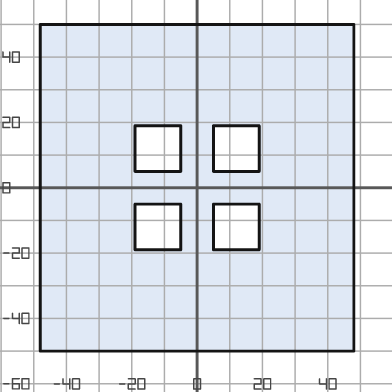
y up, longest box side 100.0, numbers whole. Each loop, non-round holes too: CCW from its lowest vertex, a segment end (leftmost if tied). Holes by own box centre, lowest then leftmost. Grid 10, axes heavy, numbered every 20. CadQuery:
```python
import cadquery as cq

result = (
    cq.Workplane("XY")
    .moveTo(-48.0, -50.0)
    .lineTo(48.0, -50.0)
    .lineTo(48.0, 50.0)
    .lineTo(-48.0, 50.0)
    .close()
    .moveTo(-19.0, -19.0)
    .lineTo(-5.0, -19.0)
    .lineTo(-5.0, -5.0)
    .lineTo(-19.0, -5.0)
    .close()
    .moveTo(5.0, -19.0)
    .lineTo(19.0, -19.0)
    .lineTo(19.0, -5.0)
    .lineTo(5.0, -5.0)
    .close()
    .moveTo(-19.0, 5.0)
    .lineTo(-5.0, 5.0)
    .lineTo(-5.0, 19.0)
    .lineTo(-19.0, 19.0)
    .close()
    .moveTo(5.0, 5.0)
    .lineTo(19.0, 5.0)
    .lineTo(19.0, 19.0)
    .lineTo(5.0, 19.0)
    .close()
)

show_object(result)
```